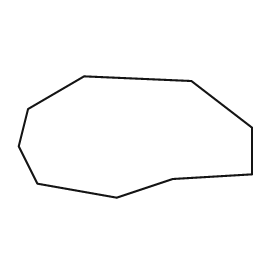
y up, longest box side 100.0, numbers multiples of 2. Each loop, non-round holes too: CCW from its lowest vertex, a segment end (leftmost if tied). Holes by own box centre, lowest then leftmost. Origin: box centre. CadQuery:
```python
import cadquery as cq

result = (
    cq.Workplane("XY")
    .moveTo(-8.0, -26.0)
    .lineTo(16.0, -18.0)
    .lineTo(50.0, -16.0)
    .lineTo(50.0, 4.0)
    .lineTo(24.0, 24.0)
    .lineTo(-22.0, 26.0)
    .lineTo(-46.0, 12.0)
    .lineTo(-50.0, -4.0)
    .lineTo(-42.0, -20.0)
    .close()
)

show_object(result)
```